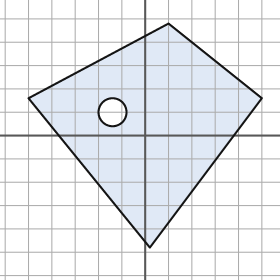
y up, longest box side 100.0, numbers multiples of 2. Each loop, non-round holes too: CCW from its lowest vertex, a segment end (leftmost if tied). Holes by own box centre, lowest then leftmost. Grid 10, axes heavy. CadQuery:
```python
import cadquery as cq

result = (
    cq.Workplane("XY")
    .moveTo(2.0, -48.0)
    .lineTo(50.0, 16.0)
    .lineTo(10.0, 48.0)
    .lineTo(-50.0, 16.0)
    .close()
    .moveTo(-14.0, 10.0)
    .circle(6.0)
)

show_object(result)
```